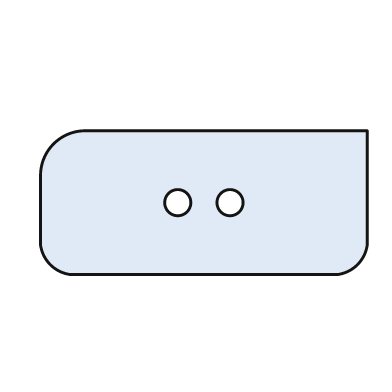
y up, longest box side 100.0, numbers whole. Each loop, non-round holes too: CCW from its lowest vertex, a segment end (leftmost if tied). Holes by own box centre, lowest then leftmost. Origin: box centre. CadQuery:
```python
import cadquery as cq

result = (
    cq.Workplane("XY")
    .moveTo(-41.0, -22.0)
    .lineTo(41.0, -22.0)
    .threePointArc((47.0, -19.0), (50.0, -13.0))
    .lineTo(50.0, 22.0)
    .lineTo(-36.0, 22.0)
    .threePointArc((-46.0, 18.0), (-50.0, 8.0))
    .lineTo(-50.0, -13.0)
    .threePointArc((-47.0, -19.0), (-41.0, -22.0))
    .close()
    .moveTo(-8.0, 0.0)
    .circle(4.0)
    .moveTo(8.0, 0.0)
    .circle(4.0)
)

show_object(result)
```